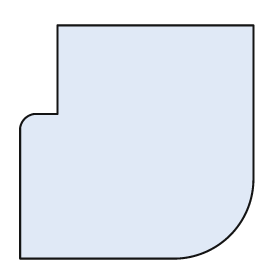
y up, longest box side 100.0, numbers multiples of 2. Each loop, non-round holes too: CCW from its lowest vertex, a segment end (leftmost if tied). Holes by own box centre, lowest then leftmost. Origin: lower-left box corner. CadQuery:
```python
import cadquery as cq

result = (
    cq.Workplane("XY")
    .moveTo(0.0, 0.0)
    .lineTo(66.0, 0.0)
    .threePointArc((90.0, 10.0), (100.0, 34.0))
    .lineTo(100.0, 100.0)
    .lineTo(16.0, 100.0)
    .lineTo(16.0, 62.0)
    .lineTo(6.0, 62.0)
    .threePointArc((2.0, 60.0), (0.0, 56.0))
    .close()
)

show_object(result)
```